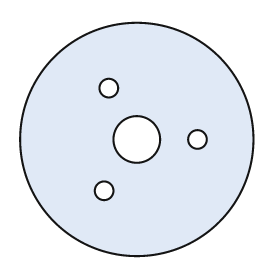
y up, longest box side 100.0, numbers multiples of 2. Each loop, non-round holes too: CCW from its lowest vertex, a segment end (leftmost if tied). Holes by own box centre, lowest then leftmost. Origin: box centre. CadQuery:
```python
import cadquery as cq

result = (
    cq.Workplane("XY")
    .moveTo(0.0, 0.0)
    .circle(50.0)
    .moveTo(-14.0, -22.0)
    .circle(4.0)
    .moveTo(0.0, 0.0)
    .circle(10.0)
    .moveTo(26.0, 0.0)
    .circle(4.0)
    .moveTo(-12.0, 22.0)
    .circle(4.0)
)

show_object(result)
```